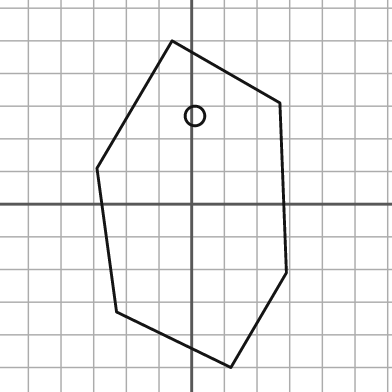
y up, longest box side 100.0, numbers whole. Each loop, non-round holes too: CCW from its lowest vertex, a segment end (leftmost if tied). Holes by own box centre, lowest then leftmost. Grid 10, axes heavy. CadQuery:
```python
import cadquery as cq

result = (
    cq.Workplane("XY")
    .moveTo(12.0, -50.0)
    .lineTo(29.0, -21.0)
    .lineTo(27.0, 31.0)
    .lineTo(-6.0, 50.0)
    .lineTo(-29.0, 11.0)
    .lineTo(-23.0, -33.0)
    .close()
    .moveTo(1.0, 27.0)
    .circle(3.0)
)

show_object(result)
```